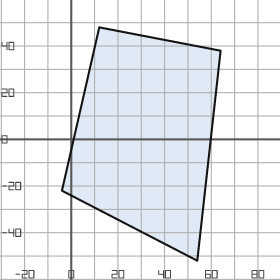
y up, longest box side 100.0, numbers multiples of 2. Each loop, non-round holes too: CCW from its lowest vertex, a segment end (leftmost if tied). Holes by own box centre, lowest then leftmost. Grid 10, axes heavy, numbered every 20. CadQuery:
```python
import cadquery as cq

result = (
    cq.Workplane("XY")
    .moveTo(54.0, -52.0)
    .lineTo(64.0, 38.0)
    .lineTo(12.0, 48.0)
    .lineTo(-4.0, -22.0)
    .close()
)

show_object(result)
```